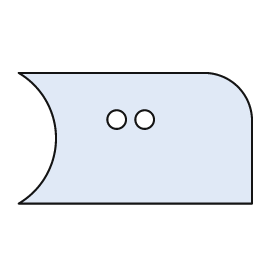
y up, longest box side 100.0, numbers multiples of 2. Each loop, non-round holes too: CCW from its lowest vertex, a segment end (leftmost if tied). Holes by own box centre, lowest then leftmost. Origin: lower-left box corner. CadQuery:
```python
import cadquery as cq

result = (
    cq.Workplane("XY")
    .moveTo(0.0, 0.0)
    .lineTo(100.0, 0.0)
    .lineTo(100.0, 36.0)
    .threePointArc((94.0, 50.0), (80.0, 56.0))
    .lineTo(0.0, 56.0)
    .threePointArc((16.0, 28.0), (0.0, 0.0))
    .close()
    .moveTo(42.0, 36.0)
    .circle(4.0)
    .moveTo(54.0, 36.0)
    .circle(4.0)
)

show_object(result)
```